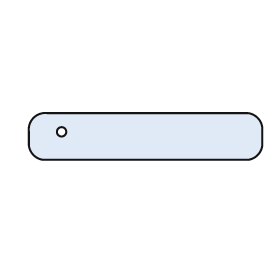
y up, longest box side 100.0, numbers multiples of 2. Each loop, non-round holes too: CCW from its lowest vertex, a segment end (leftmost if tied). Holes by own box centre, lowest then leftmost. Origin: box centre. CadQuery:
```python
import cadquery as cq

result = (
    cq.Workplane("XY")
    .moveTo(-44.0, -10.0)
    .lineTo(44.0, -10.0)
    .threePointArc((48.0, -8.0), (50.0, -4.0))
    .lineTo(50.0, 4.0)
    .threePointArc((48.0, 8.0), (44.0, 10.0))
    .lineTo(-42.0, 10.0)
    .threePointArc((-48.0, 8.0), (-50.0, 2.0))
    .lineTo(-50.0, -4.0)
    .threePointArc((-48.0, -8.0), (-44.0, -10.0))
    .close()
    .moveTo(-36.0, 2.0)
    .circle(2.0)
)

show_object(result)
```